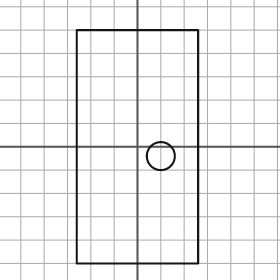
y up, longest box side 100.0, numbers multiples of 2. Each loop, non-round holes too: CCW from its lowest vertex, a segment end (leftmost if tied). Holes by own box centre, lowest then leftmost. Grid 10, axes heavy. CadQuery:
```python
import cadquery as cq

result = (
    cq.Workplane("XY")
    .moveTo(-26.0, -50.0)
    .lineTo(26.0, -50.0)
    .lineTo(26.0, 50.0)
    .lineTo(-26.0, 50.0)
    .close()
    .moveTo(10.0, -4.0)
    .circle(6.0)
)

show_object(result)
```